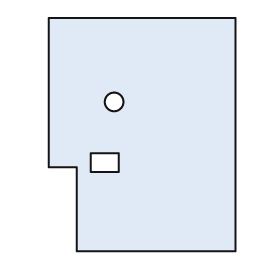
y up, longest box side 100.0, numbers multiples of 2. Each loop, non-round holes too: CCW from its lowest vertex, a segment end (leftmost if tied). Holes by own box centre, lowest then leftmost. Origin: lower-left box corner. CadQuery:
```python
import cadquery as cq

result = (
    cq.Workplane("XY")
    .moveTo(12.0, 0.0)
    .lineTo(80.0, 0.0)
    .lineTo(80.0, 100.0)
    .lineTo(0.0, 100.0)
    .lineTo(0.0, 36.0)
    .lineTo(12.0, 36.0)
    .close()
    .moveTo(18.0, 34.0)
    .lineTo(30.0, 34.0)
    .lineTo(30.0, 42.0)
    .lineTo(18.0, 42.0)
    .close()
    .moveTo(28.0, 64.0)
    .circle(4.0)
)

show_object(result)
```